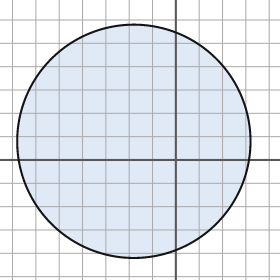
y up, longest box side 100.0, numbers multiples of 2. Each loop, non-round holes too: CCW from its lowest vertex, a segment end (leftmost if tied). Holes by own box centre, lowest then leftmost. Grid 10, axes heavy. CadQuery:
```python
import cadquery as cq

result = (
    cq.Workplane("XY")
    .moveTo(-18.0, 8.0)
    .circle(50.0)
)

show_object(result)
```